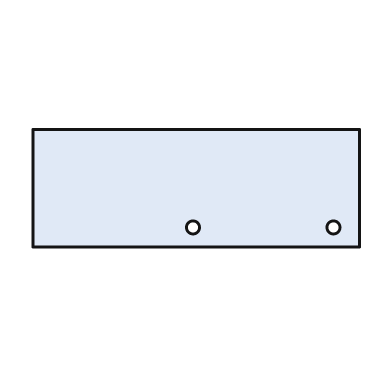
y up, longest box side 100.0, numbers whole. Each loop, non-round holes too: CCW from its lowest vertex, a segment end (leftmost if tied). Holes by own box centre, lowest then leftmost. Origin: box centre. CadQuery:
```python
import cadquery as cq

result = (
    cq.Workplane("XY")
    .moveTo(-50.0, -18.0)
    .lineTo(50.0, -18.0)
    .lineTo(50.0, 18.0)
    .lineTo(-50.0, 18.0)
    .close()
    .moveTo(-1.0, -12.0)
    .circle(2.0)
    .moveTo(42.0, -12.0)
    .circle(2.0)
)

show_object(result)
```